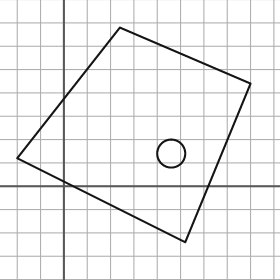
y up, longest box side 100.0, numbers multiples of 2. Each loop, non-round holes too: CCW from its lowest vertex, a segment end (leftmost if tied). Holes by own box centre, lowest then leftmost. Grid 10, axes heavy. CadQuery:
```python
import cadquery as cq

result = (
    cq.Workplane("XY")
    .moveTo(52.0, -24.0)
    .lineTo(80.0, 44.0)
    .lineTo(24.0, 68.0)
    .lineTo(-20.0, 12.0)
    .close()
    .moveTo(46.0, 14.0)
    .circle(6.0)
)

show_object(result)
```